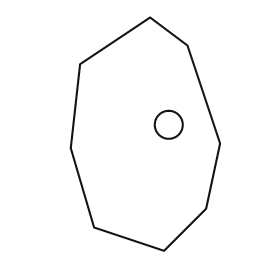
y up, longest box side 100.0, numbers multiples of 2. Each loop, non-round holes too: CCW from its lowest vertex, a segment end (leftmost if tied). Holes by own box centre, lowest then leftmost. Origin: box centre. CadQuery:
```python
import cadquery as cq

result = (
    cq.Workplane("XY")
    .moveTo(8.0, -50.0)
    .lineTo(26.0, -32.0)
    .lineTo(32.0, -4.0)
    .lineTo(18.0, 38.0)
    .lineTo(2.0, 50.0)
    .lineTo(-28.0, 30.0)
    .lineTo(-32.0, -6.0)
    .lineTo(-22.0, -40.0)
    .close()
    .moveTo(10.0, 4.0)
    .circle(6.0)
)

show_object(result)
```